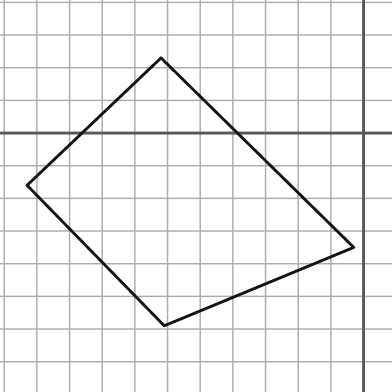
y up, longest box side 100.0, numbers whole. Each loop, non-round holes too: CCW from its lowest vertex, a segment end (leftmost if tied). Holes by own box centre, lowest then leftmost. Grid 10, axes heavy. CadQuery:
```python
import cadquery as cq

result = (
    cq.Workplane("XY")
    .moveTo(-61.0, -59.0)
    .lineTo(-3.0, -35.0)
    .lineTo(-62.0, 23.0)
    .lineTo(-103.0, -16.0)
    .close()
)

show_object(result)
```